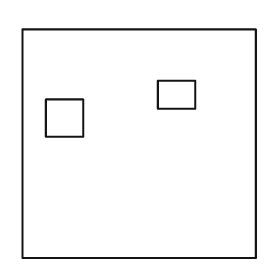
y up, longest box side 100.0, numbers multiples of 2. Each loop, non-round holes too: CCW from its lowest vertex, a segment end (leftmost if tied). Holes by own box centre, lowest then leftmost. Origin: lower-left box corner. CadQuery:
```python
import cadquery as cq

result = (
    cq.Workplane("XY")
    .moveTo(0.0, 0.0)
    .lineTo(100.0, 0.0)
    .lineTo(100.0, 98.0)
    .lineTo(0.0, 98.0)
    .close()
    .moveTo(10.0, 52.0)
    .lineTo(26.0, 52.0)
    .lineTo(26.0, 68.0)
    .lineTo(10.0, 68.0)
    .close()
    .moveTo(58.0, 64.0)
    .lineTo(74.0, 64.0)
    .lineTo(74.0, 76.0)
    .lineTo(58.0, 76.0)
    .close()
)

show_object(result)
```